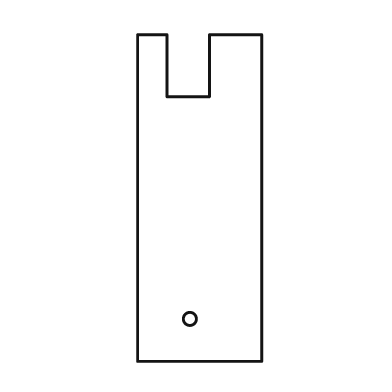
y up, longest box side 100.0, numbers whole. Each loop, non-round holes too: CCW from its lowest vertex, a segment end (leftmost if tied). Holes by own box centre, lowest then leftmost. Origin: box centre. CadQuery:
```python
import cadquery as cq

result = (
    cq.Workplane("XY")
    .moveTo(-19.0, -50.0)
    .lineTo(19.0, -50.0)
    .lineTo(19.0, 50.0)
    .lineTo(3.0, 50.0)
    .lineTo(3.0, 31.0)
    .lineTo(-10.0, 31.0)
    .lineTo(-10.0, 50.0)
    .lineTo(-19.0, 50.0)
    .close()
    .moveTo(-3.0, -37.0)
    .circle(2.0)
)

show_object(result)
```